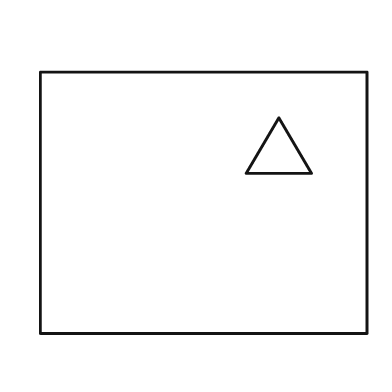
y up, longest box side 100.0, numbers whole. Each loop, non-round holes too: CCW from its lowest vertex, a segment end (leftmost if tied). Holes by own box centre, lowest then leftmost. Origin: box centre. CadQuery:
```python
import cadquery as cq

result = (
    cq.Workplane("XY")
    .moveTo(-50.0, -40.0)
    .lineTo(50.0, -40.0)
    .lineTo(50.0, 40.0)
    .lineTo(-50.0, 40.0)
    .close()
    .moveTo(13.0, 9.0)
    .lineTo(33.0, 9.0)
    .lineTo(23.0, 26.0)
    .close()
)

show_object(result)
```